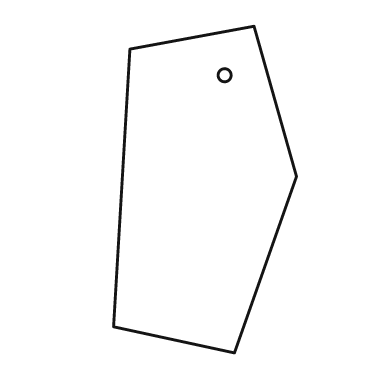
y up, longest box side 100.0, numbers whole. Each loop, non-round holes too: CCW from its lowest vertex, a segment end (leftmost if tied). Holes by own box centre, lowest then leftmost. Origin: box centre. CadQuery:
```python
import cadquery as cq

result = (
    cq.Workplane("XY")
    .moveTo(9.0, -50.0)
    .lineTo(28.0, 4.0)
    .lineTo(15.0, 50.0)
    .lineTo(-23.0, 43.0)
    .lineTo(-28.0, -42.0)
    .close()
    .moveTo(6.0, 35.0)
    .circle(2.0)
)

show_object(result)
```